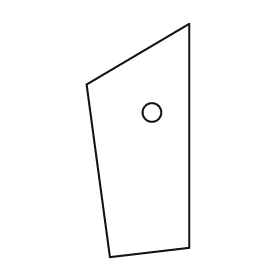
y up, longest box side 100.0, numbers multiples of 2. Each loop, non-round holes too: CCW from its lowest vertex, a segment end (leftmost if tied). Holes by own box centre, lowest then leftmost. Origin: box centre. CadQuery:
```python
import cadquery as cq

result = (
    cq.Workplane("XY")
    .moveTo(-12.0, -50.0)
    .lineTo(22.0, -46.0)
    .lineTo(22.0, 50.0)
    .lineTo(-22.0, 24.0)
    .close()
    .moveTo(6.0, 12.0)
    .circle(4.0)
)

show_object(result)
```